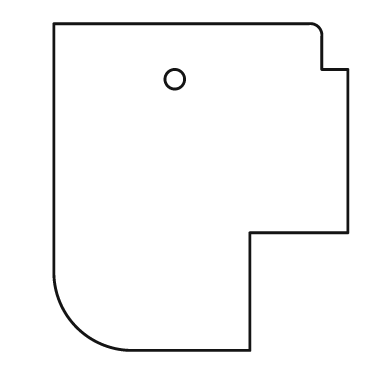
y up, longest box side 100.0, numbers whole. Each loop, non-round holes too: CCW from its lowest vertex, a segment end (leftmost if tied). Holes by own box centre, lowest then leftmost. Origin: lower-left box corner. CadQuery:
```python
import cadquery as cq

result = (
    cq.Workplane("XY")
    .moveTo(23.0, 0.0)
    .lineTo(60.0, 0.0)
    .lineTo(60.0, 36.0)
    .lineTo(90.0, 36.0)
    .lineTo(90.0, 86.0)
    .lineTo(82.0, 86.0)
    .lineTo(82.0, 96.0)
    .threePointArc((81.0, 99.0), (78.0, 100.0))
    .lineTo(0.0, 100.0)
    .lineTo(0.0, 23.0)
    .threePointArc((7.0, 7.0), (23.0, 0.0))
    .close()
    .moveTo(37.0, 83.0)
    .circle(3.0)
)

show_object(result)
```